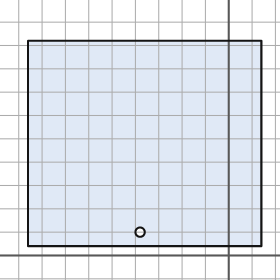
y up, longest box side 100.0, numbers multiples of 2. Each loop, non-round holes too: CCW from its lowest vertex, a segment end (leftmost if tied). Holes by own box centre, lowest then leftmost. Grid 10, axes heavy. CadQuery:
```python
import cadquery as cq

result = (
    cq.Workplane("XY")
    .moveTo(-86.0, 4.0)
    .lineTo(14.0, 4.0)
    .lineTo(14.0, 92.0)
    .lineTo(-86.0, 92.0)
    .close()
    .moveTo(-38.0, 10.0)
    .circle(2.0)
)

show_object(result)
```